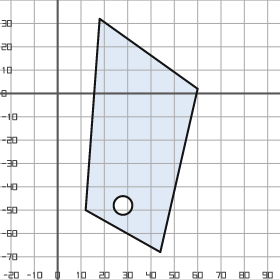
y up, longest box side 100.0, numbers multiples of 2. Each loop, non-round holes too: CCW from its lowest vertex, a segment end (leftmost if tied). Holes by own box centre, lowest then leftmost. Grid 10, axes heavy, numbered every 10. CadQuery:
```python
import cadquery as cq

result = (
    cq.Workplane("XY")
    .moveTo(44.0, -68.0)
    .lineTo(60.0, 2.0)
    .lineTo(18.0, 32.0)
    .lineTo(12.0, -50.0)
    .close()
    .moveTo(28.0, -48.0)
    .circle(4.0)
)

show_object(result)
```